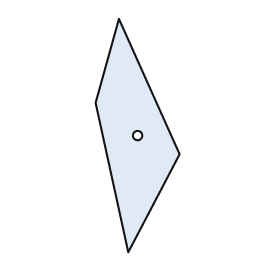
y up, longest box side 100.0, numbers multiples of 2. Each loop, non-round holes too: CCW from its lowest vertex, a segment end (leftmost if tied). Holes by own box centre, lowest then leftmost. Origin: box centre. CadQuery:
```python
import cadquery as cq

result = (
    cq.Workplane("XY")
    .moveTo(-4.0, -50.0)
    .lineTo(18.0, -8.0)
    .lineTo(-8.0, 50.0)
    .lineTo(-18.0, 14.0)
    .close()
    .moveTo(0.0, 0.0)
    .circle(2.0)
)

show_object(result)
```